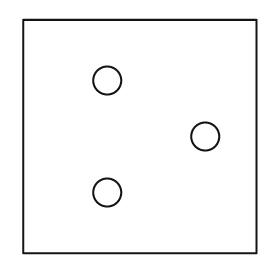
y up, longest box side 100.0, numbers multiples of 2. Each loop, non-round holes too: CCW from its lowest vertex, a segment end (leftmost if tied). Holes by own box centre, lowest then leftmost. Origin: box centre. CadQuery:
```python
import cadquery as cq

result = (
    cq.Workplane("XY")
    .moveTo(-50.0, -50.0)
    .lineTo(50.0, -50.0)
    .lineTo(50.0, 50.0)
    .lineTo(-50.0, 50.0)
    .close()
    .moveTo(-14.0, -24.0)
    .circle(6.0)
    .moveTo(28.0, 0.0)
    .circle(6.0)
    .moveTo(-14.0, 24.0)
    .circle(6.0)
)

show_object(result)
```